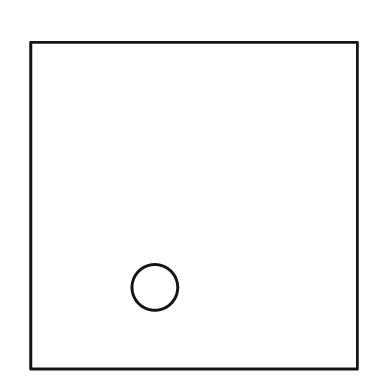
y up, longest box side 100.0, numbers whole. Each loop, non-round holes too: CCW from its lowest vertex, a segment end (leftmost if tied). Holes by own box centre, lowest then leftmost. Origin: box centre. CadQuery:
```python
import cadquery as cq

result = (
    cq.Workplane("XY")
    .moveTo(-50.0, -50.0)
    .lineTo(50.0, -50.0)
    .lineTo(50.0, 50.0)
    .lineTo(-50.0, 50.0)
    .close()
    .moveTo(-12.0, -25.0)
    .circle(7.0)
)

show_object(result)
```